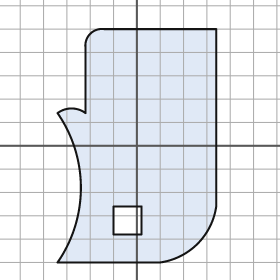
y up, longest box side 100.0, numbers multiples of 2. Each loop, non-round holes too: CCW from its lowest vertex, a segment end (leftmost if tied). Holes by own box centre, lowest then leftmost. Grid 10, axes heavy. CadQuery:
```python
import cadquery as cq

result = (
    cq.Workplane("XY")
    .moveTo(-34.0, -50.0)
    .lineTo(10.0, -50.0)
    .threePointArc((26.0, -42.0), (34.0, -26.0))
    .lineTo(34.0, 50.0)
    .lineTo(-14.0, 50.0)
    .threePointArc((-20.0, 48.0), (-22.0, 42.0))
    .lineTo(-22.0, 14.0)
    .threePointArc((-28.0, 16.0), (-34.0, 14.0))
    .threePointArc((-24.0, -18.0), (-34.0, -50.0))
    .close()
    .moveTo(-10.0, -38.0)
    .lineTo(2.0, -38.0)
    .lineTo(2.0, -26.0)
    .lineTo(-10.0, -26.0)
    .close()
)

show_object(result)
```